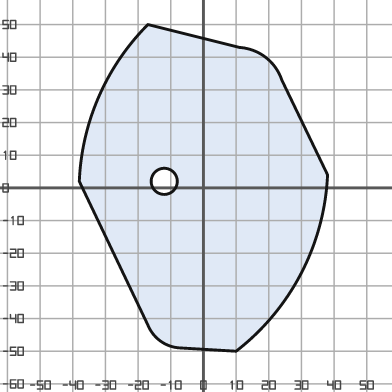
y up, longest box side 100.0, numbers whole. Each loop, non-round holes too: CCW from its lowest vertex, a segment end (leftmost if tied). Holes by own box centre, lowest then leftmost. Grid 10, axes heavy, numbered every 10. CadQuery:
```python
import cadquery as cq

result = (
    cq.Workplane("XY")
    .moveTo(10.0, -50.0)
    .threePointArc((30.0, -26.0), (38.0, 4.0))
    .lineTo(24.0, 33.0)
    .threePointArc((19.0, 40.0), (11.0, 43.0))
    .lineTo(-17.0, 50.0)
    .threePointArc((-32.0, 28.0), (-38.0, 2.0))
    .lineTo(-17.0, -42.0)
    .threePointArc((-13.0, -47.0), (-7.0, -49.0))
    .close()
    .moveTo(-12.0, 2.0)
    .circle(4.0)
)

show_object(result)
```